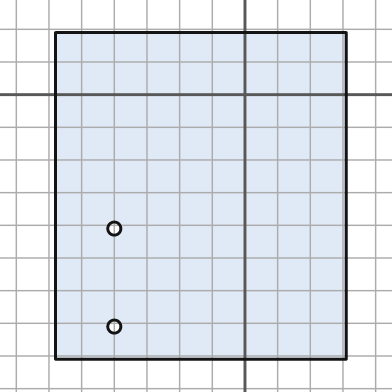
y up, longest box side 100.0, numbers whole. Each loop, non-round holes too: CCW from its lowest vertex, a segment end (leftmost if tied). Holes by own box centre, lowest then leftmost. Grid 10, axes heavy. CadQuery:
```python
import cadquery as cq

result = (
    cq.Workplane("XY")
    .moveTo(-58.0, -81.0)
    .lineTo(31.0, -81.0)
    .lineTo(31.0, 19.0)
    .lineTo(-58.0, 19.0)
    .close()
    .moveTo(-40.0, -71.0)
    .circle(2.0)
    .moveTo(-40.0, -41.0)
    .circle(2.0)
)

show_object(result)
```